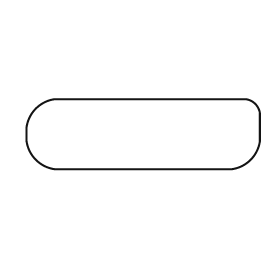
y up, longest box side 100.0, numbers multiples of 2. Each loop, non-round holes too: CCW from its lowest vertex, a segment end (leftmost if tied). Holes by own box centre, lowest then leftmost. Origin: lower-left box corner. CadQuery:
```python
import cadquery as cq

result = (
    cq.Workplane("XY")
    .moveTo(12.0, 0.0)
    .lineTo(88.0, 0.0)
    .threePointArc((96.0, 4.0), (100.0, 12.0))
    .lineTo(100.0, 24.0)
    .threePointArc((98.0, 28.0), (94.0, 30.0))
    .lineTo(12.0, 30.0)
    .threePointArc((4.0, 26.0), (0.0, 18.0))
    .lineTo(0.0, 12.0)
    .threePointArc((4.0, 4.0), (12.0, 0.0))
    .close()
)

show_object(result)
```